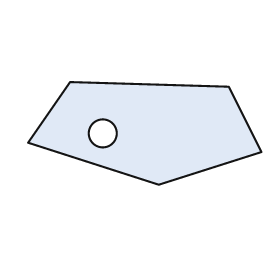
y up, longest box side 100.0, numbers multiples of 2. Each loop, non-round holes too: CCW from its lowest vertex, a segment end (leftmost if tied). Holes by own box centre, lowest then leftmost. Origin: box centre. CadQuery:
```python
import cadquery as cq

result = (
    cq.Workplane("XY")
    .moveTo(6.0, -22.0)
    .lineTo(50.0, -8.0)
    .lineTo(36.0, 20.0)
    .lineTo(-32.0, 22.0)
    .lineTo(-50.0, -4.0)
    .close()
    .moveTo(-18.0, 0.0)
    .circle(6.0)
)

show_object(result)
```